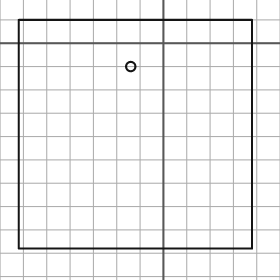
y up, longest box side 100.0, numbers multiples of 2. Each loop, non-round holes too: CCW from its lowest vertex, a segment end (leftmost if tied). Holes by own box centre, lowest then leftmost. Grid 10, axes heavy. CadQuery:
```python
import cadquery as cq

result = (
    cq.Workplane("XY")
    .moveTo(-62.0, -88.0)
    .lineTo(38.0, -88.0)
    .lineTo(38.0, 10.0)
    .lineTo(-62.0, 10.0)
    .close()
    .moveTo(-14.0, -10.0)
    .circle(2.0)
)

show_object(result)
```